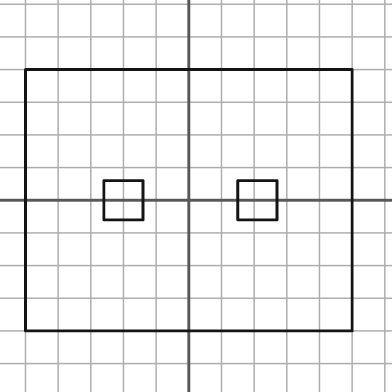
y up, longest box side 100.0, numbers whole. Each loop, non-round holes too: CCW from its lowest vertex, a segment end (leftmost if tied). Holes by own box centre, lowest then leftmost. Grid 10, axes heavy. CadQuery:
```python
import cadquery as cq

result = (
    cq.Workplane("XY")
    .moveTo(-50.0, -40.0)
    .lineTo(50.0, -40.0)
    .lineTo(50.0, 40.0)
    .lineTo(-50.0, 40.0)
    .close()
    .moveTo(-26.0, -6.0)
    .lineTo(-14.0, -6.0)
    .lineTo(-14.0, 6.0)
    .lineTo(-26.0, 6.0)
    .close()
    .moveTo(15.0, -6.0)
    .lineTo(27.0, -6.0)
    .lineTo(27.0, 6.0)
    .lineTo(15.0, 6.0)
    .close()
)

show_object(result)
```